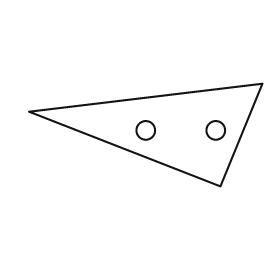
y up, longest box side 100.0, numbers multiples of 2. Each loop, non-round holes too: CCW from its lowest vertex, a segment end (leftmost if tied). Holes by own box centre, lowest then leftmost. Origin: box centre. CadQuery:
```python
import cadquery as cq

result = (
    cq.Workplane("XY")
    .moveTo(32.0, -22.0)
    .lineTo(50.0, 22.0)
    .lineTo(-50.0, 10.0)
    .close()
    .moveTo(0.0, 2.0)
    .circle(4.0)
    .moveTo(30.0, 2.0)
    .circle(4.0)
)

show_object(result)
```